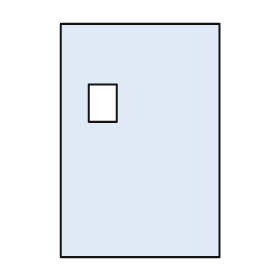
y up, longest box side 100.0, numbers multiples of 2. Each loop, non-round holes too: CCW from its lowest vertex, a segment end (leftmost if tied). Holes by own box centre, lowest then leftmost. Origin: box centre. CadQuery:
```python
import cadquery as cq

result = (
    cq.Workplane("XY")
    .moveTo(-34.0, -50.0)
    .lineTo(34.0, -50.0)
    .lineTo(34.0, 50.0)
    .lineTo(-34.0, 50.0)
    .close()
    .moveTo(-22.0, 8.0)
    .lineTo(-10.0, 8.0)
    .lineTo(-10.0, 24.0)
    .lineTo(-22.0, 24.0)
    .close()
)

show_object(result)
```